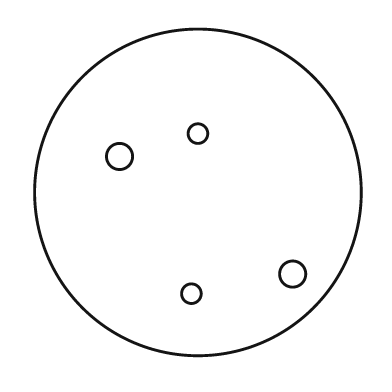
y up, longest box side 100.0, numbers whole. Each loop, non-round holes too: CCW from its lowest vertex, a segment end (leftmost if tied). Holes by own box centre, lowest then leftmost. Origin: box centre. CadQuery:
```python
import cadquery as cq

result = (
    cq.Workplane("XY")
    .moveTo(0.0, 0.0)
    .circle(50.0)
    .moveTo(-2.0, -31.0)
    .circle(3.0)
    .moveTo(29.0, -25.0)
    .circle(4.0)
    .moveTo(-24.0, 11.0)
    .circle(4.0)
    .moveTo(0.0, 18.0)
    .circle(3.0)
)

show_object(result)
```